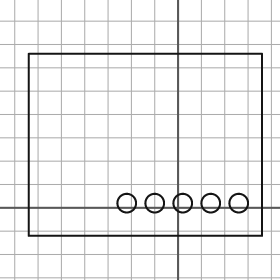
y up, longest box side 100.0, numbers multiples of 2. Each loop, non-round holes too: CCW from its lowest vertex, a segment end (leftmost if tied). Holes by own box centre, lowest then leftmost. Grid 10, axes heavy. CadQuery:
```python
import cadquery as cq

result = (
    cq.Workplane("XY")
    .moveTo(-64.0, -12.0)
    .lineTo(36.0, -12.0)
    .lineTo(36.0, 66.0)
    .lineTo(-64.0, 66.0)
    .close()
    .moveTo(-22.0, 2.0)
    .circle(4.0)
    .moveTo(-10.0, 2.0)
    .circle(4.0)
    .moveTo(2.0, 2.0)
    .circle(4.0)
    .moveTo(14.0, 2.0)
    .circle(4.0)
    .moveTo(26.0, 2.0)
    .circle(4.0)
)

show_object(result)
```